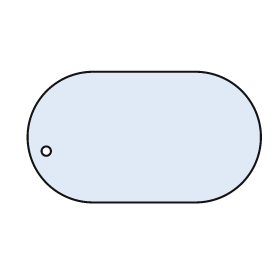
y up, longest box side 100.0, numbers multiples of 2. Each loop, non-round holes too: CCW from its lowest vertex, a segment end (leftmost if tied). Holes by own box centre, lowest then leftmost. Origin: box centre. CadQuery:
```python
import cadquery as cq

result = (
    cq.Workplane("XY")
    .moveTo(-22.0, -28.0)
    .lineTo(22.0, -28.0)
    .threePointArc((50.0, 0.0), (22.0, 28.0))
    .lineTo(-22.0, 28.0)
    .threePointArc((-50.0, 0.0), (-22.0, -28.0))
    .close()
    .moveTo(-42.0, -6.0)
    .circle(2.0)
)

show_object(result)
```